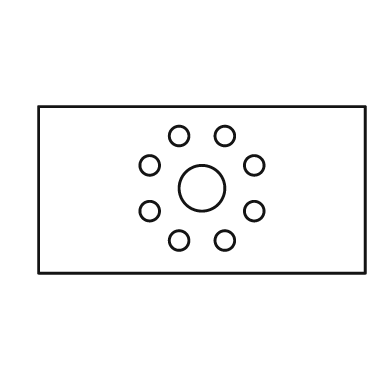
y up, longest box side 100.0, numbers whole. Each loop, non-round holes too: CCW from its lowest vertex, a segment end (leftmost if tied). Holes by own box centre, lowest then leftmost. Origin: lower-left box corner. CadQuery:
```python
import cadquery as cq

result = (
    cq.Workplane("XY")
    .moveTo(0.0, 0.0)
    .lineTo(100.0, 0.0)
    .lineTo(100.0, 51.0)
    .lineTo(0.0, 51.0)
    .close()
    .moveTo(43.0, 10.0)
    .circle(3.0)
    .moveTo(57.0, 10.0)
    .circle(3.0)
    .moveTo(34.0, 19.0)
    .circle(3.0)
    .moveTo(66.0, 19.0)
    .circle(3.0)
    .moveTo(50.0, 26.0)
    .circle(7.0)
    .moveTo(34.0, 33.0)
    .circle(3.0)
    .moveTo(66.0, 33.0)
    .circle(3.0)
    .moveTo(43.0, 42.0)
    .circle(3.0)
    .moveTo(57.0, 42.0)
    .circle(3.0)
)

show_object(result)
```